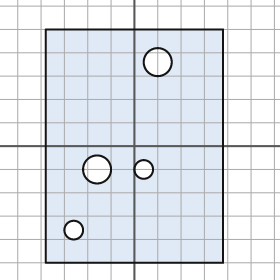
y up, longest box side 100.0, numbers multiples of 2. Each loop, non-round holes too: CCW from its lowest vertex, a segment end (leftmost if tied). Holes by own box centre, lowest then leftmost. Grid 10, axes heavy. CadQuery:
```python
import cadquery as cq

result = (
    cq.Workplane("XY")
    .moveTo(-38.0, -50.0)
    .lineTo(38.0, -50.0)
    .lineTo(38.0, 50.0)
    .lineTo(-38.0, 50.0)
    .close()
    .moveTo(-26.0, -36.0)
    .circle(4.0)
    .moveTo(-16.0, -10.0)
    .circle(6.0)
    .moveTo(4.0, -10.0)
    .circle(4.0)
    .moveTo(10.0, 36.0)
    .circle(6.0)
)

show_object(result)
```